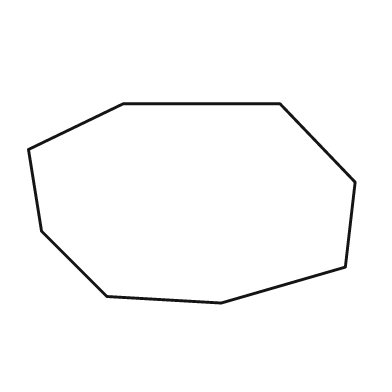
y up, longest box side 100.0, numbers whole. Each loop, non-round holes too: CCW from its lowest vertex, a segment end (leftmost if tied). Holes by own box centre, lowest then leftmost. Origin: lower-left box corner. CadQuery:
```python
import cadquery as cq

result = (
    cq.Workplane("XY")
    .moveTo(59.0, 0.0)
    .lineTo(97.0, 11.0)
    .lineTo(100.0, 37.0)
    .lineTo(77.0, 61.0)
    .lineTo(29.0, 61.0)
    .lineTo(0.0, 47.0)
    .lineTo(4.0, 22.0)
    .lineTo(24.0, 2.0)
    .close()
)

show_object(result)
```